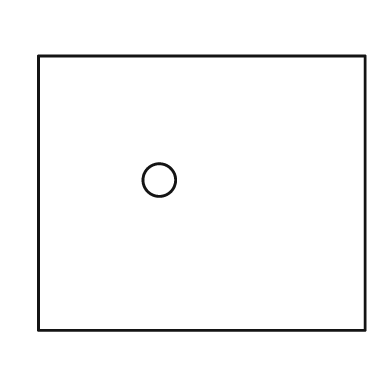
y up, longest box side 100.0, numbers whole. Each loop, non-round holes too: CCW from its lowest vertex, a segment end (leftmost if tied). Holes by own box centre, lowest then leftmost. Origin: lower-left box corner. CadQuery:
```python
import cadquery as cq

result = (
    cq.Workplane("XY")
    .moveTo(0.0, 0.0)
    .lineTo(100.0, 0.0)
    .lineTo(100.0, 84.0)
    .lineTo(0.0, 84.0)
    .close()
    .moveTo(37.0, 46.0)
    .circle(5.0)
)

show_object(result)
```